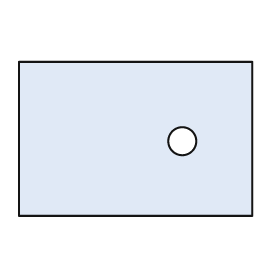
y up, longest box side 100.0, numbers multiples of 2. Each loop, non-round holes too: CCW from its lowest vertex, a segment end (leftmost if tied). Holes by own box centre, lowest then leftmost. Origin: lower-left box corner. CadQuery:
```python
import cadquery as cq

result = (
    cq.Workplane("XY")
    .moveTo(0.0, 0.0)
    .lineTo(100.0, 0.0)
    .lineTo(100.0, 66.0)
    .lineTo(0.0, 66.0)
    .close()
    .moveTo(70.0, 32.0)
    .circle(6.0)
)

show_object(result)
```